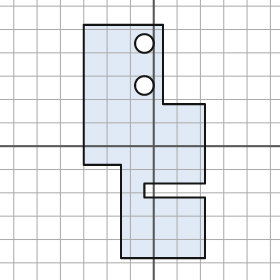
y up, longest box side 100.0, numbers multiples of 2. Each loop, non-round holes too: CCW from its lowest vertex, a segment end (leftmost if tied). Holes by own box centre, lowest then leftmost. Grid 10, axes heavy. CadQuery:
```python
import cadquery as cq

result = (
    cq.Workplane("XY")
    .moveTo(-14.0, -48.0)
    .lineTo(22.0, -48.0)
    .lineTo(22.0, -22.0)
    .lineTo(-4.0, -22.0)
    .lineTo(-4.0, -16.0)
    .lineTo(22.0, -16.0)
    .lineTo(22.0, 18.0)
    .lineTo(4.0, 18.0)
    .lineTo(4.0, 52.0)
    .lineTo(-30.0, 52.0)
    .lineTo(-30.0, -8.0)
    .lineTo(-14.0, -8.0)
    .close()
    .moveTo(-4.0, 26.0)
    .circle(4.0)
    .moveTo(-4.0, 44.0)
    .circle(4.0)
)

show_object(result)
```